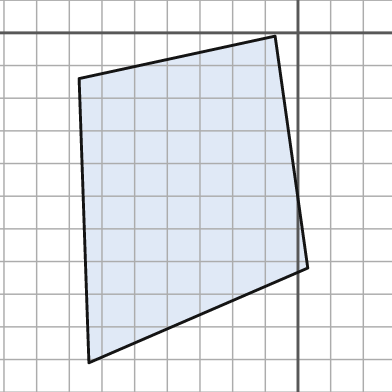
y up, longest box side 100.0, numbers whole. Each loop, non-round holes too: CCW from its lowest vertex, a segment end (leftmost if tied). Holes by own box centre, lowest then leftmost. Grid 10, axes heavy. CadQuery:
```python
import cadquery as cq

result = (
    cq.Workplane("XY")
    .moveTo(-64.0, -101.0)
    .lineTo(3.0, -72.0)
    .lineTo(-7.0, -1.0)
    .lineTo(-67.0, -14.0)
    .close()
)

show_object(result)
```